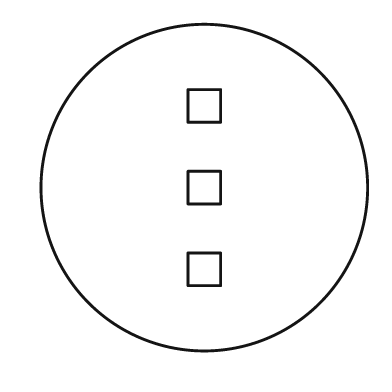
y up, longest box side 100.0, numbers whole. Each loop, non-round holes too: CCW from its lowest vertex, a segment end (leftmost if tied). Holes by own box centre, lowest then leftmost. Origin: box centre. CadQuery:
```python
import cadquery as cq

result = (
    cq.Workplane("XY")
    .moveTo(0.0, 0.0)
    .circle(50.0)
    .moveTo(-5.0, -30.0)
    .lineTo(5.0, -30.0)
    .lineTo(5.0, -20.0)
    .lineTo(-5.0, -20.0)
    .close()
    .moveTo(-5.0, -5.0)
    .lineTo(5.0, -5.0)
    .lineTo(5.0, 5.0)
    .lineTo(-5.0, 5.0)
    .close()
    .moveTo(-5.0, 20.0)
    .lineTo(5.0, 20.0)
    .lineTo(5.0, 30.0)
    .lineTo(-5.0, 30.0)
    .close()
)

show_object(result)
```